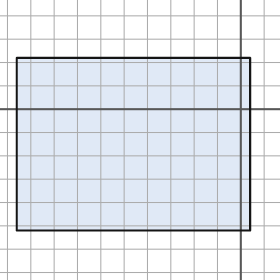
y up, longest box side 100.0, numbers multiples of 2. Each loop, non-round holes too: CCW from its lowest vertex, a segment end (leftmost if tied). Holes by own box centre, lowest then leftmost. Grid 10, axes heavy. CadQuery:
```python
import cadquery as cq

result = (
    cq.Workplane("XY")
    .moveTo(-96.0, -52.0)
    .lineTo(4.0, -52.0)
    .lineTo(4.0, 22.0)
    .lineTo(-96.0, 22.0)
    .close()
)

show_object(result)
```